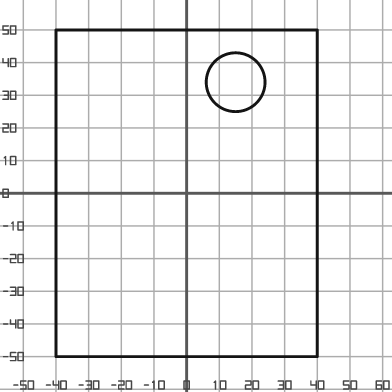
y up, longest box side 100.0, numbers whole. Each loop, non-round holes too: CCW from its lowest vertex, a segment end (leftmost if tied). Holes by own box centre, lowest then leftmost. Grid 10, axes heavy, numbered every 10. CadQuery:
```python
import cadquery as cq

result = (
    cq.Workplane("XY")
    .moveTo(-40.0, -50.0)
    .lineTo(40.0, -50.0)
    .lineTo(40.0, 50.0)
    .lineTo(-40.0, 50.0)
    .close()
    .moveTo(15.0, 34.0)
    .circle(9.0)
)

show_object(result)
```